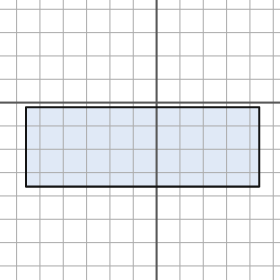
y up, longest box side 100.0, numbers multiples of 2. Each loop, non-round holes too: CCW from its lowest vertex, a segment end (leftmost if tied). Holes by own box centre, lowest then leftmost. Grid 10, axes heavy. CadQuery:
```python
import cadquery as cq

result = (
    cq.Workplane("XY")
    .moveTo(-56.0, -36.0)
    .lineTo(44.0, -36.0)
    .lineTo(44.0, -2.0)
    .lineTo(-56.0, -2.0)
    .close()
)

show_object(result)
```